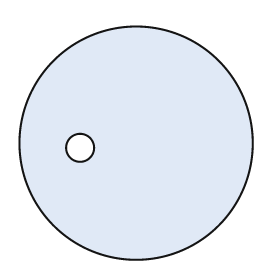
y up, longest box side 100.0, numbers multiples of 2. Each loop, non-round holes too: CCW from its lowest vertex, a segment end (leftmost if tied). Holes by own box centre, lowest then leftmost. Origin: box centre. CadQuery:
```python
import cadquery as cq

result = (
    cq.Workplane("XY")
    .moveTo(0.0, 0.0)
    .circle(50.0)
    .moveTo(-24.0, -2.0)
    .circle(6.0)
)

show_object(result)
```